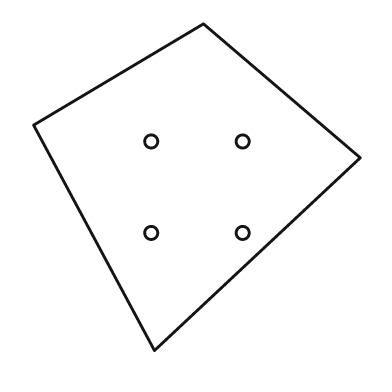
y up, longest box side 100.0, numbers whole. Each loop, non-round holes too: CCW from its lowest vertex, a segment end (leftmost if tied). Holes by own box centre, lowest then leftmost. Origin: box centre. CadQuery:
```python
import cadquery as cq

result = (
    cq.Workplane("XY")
    .moveTo(-13.0, -50.0)
    .lineTo(50.0, 9.0)
    .lineTo(2.0, 50.0)
    .lineTo(-50.0, 19.0)
    .close()
    .moveTo(-14.0, -14.0)
    .circle(2.0)
    .moveTo(14.0, -14.0)
    .circle(2.0)
    .moveTo(-14.0, 14.0)
    .circle(2.0)
    .moveTo(14.0, 14.0)
    .circle(2.0)
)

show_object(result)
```